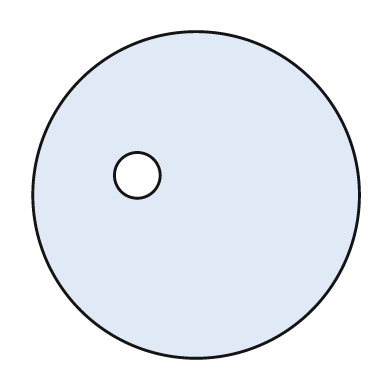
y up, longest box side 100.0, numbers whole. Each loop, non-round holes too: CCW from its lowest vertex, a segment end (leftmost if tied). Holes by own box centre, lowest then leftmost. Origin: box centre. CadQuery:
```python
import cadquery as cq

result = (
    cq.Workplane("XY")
    .moveTo(0.0, 0.0)
    .circle(50.0)
    .moveTo(-18.0, 6.0)
    .circle(7.0)
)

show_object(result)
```